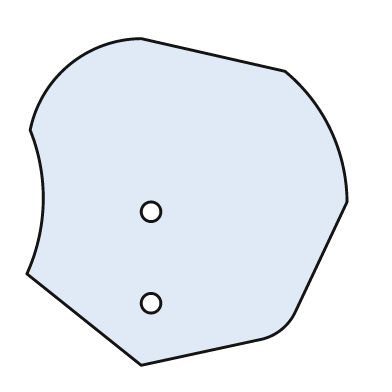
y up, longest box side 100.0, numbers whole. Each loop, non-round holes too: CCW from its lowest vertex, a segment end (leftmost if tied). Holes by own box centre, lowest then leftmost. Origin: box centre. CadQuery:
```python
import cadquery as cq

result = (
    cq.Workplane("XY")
    .moveTo(-14.0, -50.0)
    .lineTo(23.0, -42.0)
    .threePointArc((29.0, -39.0), (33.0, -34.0))
    .lineTo(49.0, 0.0)
    .threePointArc((44.0, 22.0), (30.0, 40.0))
    .lineTo(-14.0, 50.0)
    .threePointArc((-36.0, 42.0), (-48.0, 22.0))
    .threePointArc((-44.0, 0.0), (-49.0, -22.0))
    .close()
    .moveTo(-11.0, -31.0)
    .circle(3.0)
    .moveTo(-11.0, -3.0)
    .circle(3.0)
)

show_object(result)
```